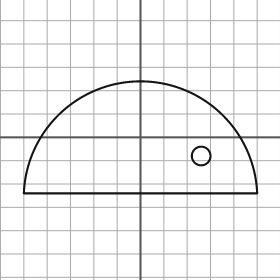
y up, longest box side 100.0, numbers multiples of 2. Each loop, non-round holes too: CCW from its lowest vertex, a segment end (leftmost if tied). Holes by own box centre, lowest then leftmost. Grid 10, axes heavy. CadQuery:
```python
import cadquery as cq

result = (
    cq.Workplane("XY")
    .moveTo(-50.0, -24.0)
    .lineTo(50.0, -24.0)
    .threePointArc((0.0, 24.0), (-50.0, -24.0))
    .close()
    .moveTo(26.0, -8.0)
    .circle(4.0)
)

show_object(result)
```